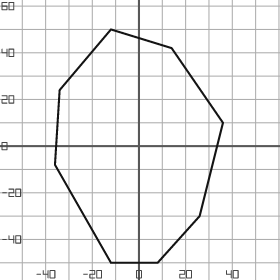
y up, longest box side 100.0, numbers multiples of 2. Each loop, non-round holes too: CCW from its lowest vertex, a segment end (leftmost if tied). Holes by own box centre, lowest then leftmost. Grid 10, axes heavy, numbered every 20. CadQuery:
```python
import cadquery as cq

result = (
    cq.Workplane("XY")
    .moveTo(-12.0, -50.0)
    .lineTo(8.0, -50.0)
    .lineTo(26.0, -30.0)
    .lineTo(36.0, 10.0)
    .lineTo(14.0, 42.0)
    .lineTo(-12.0, 50.0)
    .lineTo(-34.0, 24.0)
    .lineTo(-36.0, -8.0)
    .close()
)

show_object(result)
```